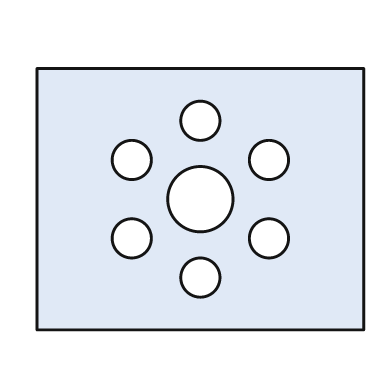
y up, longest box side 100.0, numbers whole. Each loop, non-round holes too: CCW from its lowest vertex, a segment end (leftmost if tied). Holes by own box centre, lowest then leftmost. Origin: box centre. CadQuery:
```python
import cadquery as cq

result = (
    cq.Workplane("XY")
    .moveTo(-50.0, -40.0)
    .lineTo(50.0, -40.0)
    .lineTo(50.0, 40.0)
    .lineTo(-50.0, 40.0)
    .close()
    .moveTo(0.0, -24.0)
    .circle(6.0)
    .moveTo(-21.0, -12.0)
    .circle(6.0)
    .moveTo(21.0, -12.0)
    .circle(6.0)
    .moveTo(0.0, 0.0)
    .circle(10.0)
    .moveTo(-21.0, 12.0)
    .circle(6.0)
    .moveTo(21.0, 12.0)
    .circle(6.0)
    .moveTo(0.0, 24.0)
    .circle(6.0)
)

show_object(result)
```